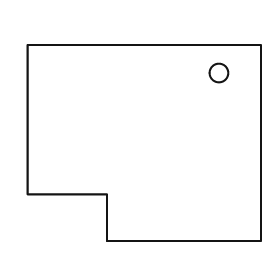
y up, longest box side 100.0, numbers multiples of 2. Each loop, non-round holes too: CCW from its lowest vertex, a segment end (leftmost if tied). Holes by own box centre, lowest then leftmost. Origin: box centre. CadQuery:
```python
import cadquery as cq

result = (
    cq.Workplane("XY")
    .moveTo(-16.0, -42.0)
    .lineTo(50.0, -42.0)
    .lineTo(50.0, 42.0)
    .lineTo(-50.0, 42.0)
    .lineTo(-50.0, -22.0)
    .lineTo(-16.0, -22.0)
    .close()
    .moveTo(32.0, 30.0)
    .circle(4.0)
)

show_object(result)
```